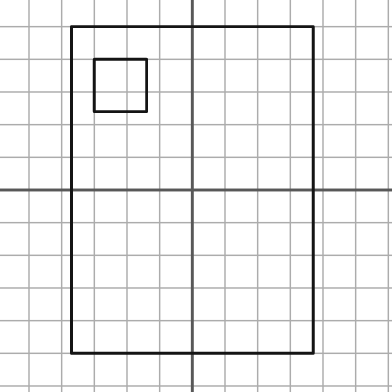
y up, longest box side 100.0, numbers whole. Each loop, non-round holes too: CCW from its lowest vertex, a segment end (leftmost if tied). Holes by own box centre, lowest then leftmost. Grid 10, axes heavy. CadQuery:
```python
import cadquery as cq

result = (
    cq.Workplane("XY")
    .moveTo(-37.0, -50.0)
    .lineTo(37.0, -50.0)
    .lineTo(37.0, 50.0)
    .lineTo(-37.0, 50.0)
    .close()
    .moveTo(-30.0, 24.0)
    .lineTo(-14.0, 24.0)
    .lineTo(-14.0, 40.0)
    .lineTo(-30.0, 40.0)
    .close()
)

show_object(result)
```